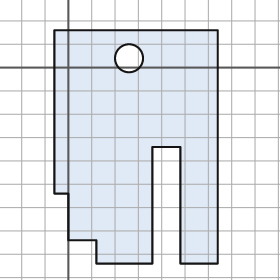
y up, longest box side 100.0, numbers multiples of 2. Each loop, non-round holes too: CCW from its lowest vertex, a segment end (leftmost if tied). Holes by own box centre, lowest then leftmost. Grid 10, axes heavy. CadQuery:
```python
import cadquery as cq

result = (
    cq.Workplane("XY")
    .moveTo(12.0, -84.0)
    .lineTo(36.0, -84.0)
    .lineTo(36.0, -34.0)
    .lineTo(48.0, -34.0)
    .lineTo(48.0, -84.0)
    .lineTo(64.0, -84.0)
    .lineTo(64.0, 16.0)
    .lineTo(-6.0, 16.0)
    .lineTo(-6.0, -54.0)
    .lineTo(0.0, -54.0)
    .lineTo(0.0, -74.0)
    .lineTo(12.0, -74.0)
    .close()
    .moveTo(26.0, 4.0)
    .circle(6.0)
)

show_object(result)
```